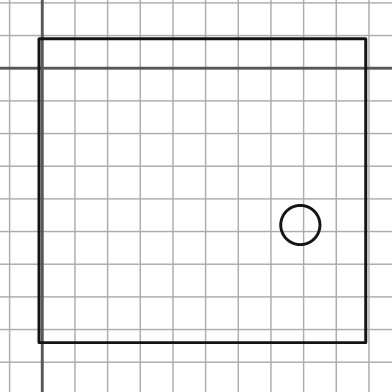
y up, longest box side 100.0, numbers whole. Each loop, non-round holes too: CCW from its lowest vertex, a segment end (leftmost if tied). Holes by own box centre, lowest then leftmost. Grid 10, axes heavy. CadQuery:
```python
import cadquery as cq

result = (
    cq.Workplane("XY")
    .moveTo(-1.0, -84.0)
    .lineTo(99.0, -84.0)
    .lineTo(99.0, 9.0)
    .lineTo(-1.0, 9.0)
    .close()
    .moveTo(79.0, -48.0)
    .circle(6.0)
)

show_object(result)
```